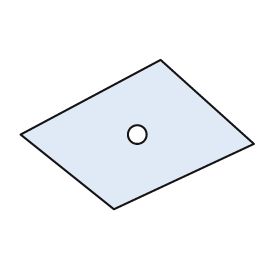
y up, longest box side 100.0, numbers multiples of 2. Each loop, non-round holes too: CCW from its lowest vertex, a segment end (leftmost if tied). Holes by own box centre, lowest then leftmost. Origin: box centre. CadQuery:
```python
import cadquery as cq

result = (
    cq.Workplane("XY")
    .moveTo(-10.0, -32.0)
    .lineTo(50.0, -4.0)
    .lineTo(10.0, 32.0)
    .lineTo(-50.0, 0.0)
    .close()
    .moveTo(0.0, 0.0)
    .circle(4.0)
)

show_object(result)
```